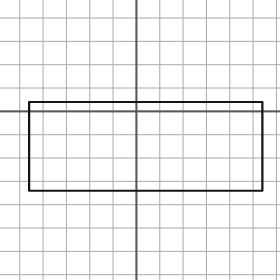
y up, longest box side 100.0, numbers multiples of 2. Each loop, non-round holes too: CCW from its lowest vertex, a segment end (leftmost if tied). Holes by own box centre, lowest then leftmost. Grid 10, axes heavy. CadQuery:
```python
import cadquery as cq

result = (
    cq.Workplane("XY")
    .moveTo(-46.0, -34.0)
    .lineTo(54.0, -34.0)
    .lineTo(54.0, 4.0)
    .lineTo(-46.0, 4.0)
    .close()
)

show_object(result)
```